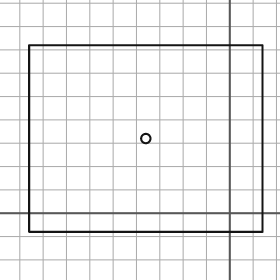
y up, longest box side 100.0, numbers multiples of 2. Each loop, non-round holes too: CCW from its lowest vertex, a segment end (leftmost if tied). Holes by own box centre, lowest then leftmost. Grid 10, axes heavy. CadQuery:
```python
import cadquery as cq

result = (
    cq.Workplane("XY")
    .moveTo(-86.0, -8.0)
    .lineTo(14.0, -8.0)
    .lineTo(14.0, 72.0)
    .lineTo(-86.0, 72.0)
    .close()
    .moveTo(-36.0, 32.0)
    .circle(2.0)
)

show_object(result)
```